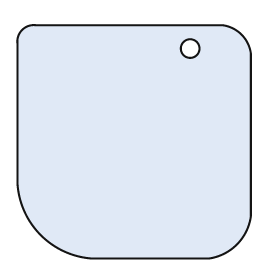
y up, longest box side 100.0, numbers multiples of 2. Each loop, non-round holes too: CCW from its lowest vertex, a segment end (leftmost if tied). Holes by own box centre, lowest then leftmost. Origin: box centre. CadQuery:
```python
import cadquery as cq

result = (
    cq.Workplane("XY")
    .moveTo(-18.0, -50.0)
    .lineTo(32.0, -50.0)
    .threePointArc((44.0, -44.0), (50.0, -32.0))
    .lineTo(50.0, 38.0)
    .threePointArc((46.0, 46.0), (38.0, 50.0))
    .lineTo(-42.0, 50.0)
    .threePointArc((-48.0, 48.0), (-50.0, 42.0))
    .lineTo(-50.0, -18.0)
    .threePointArc((-40.0, -40.0), (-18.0, -50.0))
    .close()
    .moveTo(24.0, 40.0)
    .circle(4.0)
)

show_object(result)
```